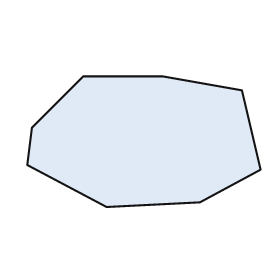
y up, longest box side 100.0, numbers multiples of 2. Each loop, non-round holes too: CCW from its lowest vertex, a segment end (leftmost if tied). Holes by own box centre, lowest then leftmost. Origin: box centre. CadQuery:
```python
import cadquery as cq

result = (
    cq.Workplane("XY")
    .moveTo(-16.0, -28.0)
    .lineTo(24.0, -26.0)
    .lineTo(50.0, -12.0)
    .lineTo(42.0, 22.0)
    .lineTo(8.0, 28.0)
    .lineTo(-26.0, 28.0)
    .lineTo(-48.0, 6.0)
    .lineTo(-50.0, -10.0)
    .close()
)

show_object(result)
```